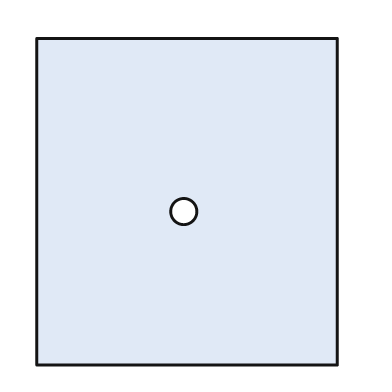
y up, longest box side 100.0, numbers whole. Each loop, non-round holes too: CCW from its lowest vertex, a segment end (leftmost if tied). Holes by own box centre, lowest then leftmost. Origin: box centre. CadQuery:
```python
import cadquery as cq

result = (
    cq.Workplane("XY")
    .moveTo(-46.0, -50.0)
    .lineTo(46.0, -50.0)
    .lineTo(46.0, 50.0)
    .lineTo(-46.0, 50.0)
    .close()
    .moveTo(-1.0, -3.0)
    .circle(4.0)
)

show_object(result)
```